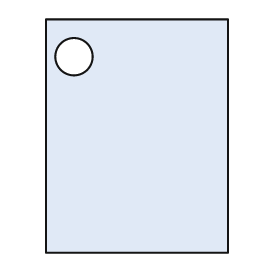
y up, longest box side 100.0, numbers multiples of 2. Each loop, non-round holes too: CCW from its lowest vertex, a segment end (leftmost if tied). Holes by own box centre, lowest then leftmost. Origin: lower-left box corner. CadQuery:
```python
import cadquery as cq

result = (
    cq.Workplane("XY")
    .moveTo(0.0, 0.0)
    .lineTo(78.0, 0.0)
    .lineTo(78.0, 100.0)
    .lineTo(0.0, 100.0)
    .close()
    .moveTo(12.0, 84.0)
    .circle(8.0)
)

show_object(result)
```